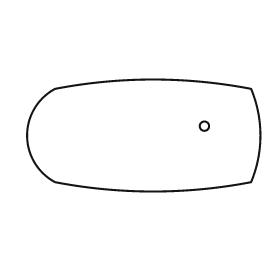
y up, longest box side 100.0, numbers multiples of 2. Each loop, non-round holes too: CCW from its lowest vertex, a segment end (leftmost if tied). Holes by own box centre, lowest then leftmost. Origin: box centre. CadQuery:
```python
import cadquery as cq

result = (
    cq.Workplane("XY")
    .moveTo(-38.0, -20.0)
    .threePointArc((4.0, -24.0), (46.0, -20.0))
    .threePointArc((50.0, 0.0), (46.0, 20.0))
    .threePointArc((4.0, 24.0), (-38.0, 20.0))
    .threePointArc((-50.0, 0.0), (-38.0, -20.0))
    .close()
    .moveTo(26.0, 4.0)
    .circle(2.0)
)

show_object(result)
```